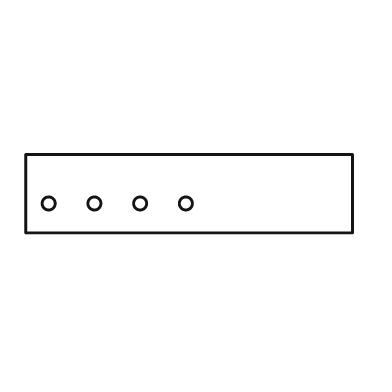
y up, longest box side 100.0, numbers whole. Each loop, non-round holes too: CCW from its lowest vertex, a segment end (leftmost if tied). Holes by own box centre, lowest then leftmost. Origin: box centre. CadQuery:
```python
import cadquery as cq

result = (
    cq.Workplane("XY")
    .moveTo(-50.0, -12.0)
    .lineTo(50.0, -12.0)
    .lineTo(50.0, 12.0)
    .lineTo(-50.0, 12.0)
    .close()
    .moveTo(-43.0, -3.0)
    .circle(2.0)
    .moveTo(-29.0, -3.0)
    .circle(2.0)
    .moveTo(-15.0, -3.0)
    .circle(2.0)
    .moveTo(-1.0, -3.0)
    .circle(2.0)
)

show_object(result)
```